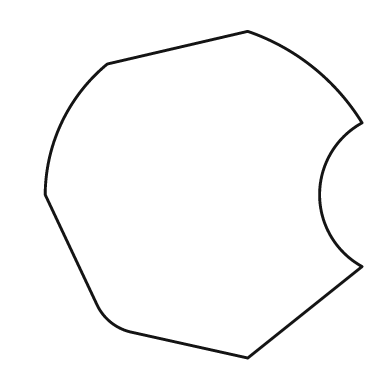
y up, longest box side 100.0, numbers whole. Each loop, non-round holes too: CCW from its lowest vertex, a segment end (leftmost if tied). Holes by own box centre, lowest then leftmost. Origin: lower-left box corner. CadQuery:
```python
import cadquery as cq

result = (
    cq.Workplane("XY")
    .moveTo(62.0, 0.0)
    .lineTo(97.0, 28.0)
    .threePointArc((84.0, 50.0), (97.0, 72.0))
    .threePointArc((82.0, 89.0), (62.0, 100.0))
    .lineTo(19.0, 90.0)
    .threePointArc((5.0, 72.0), (0.0, 50.0))
    .lineTo(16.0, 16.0)
    .threePointArc((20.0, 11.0), (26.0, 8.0))
    .close()
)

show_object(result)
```